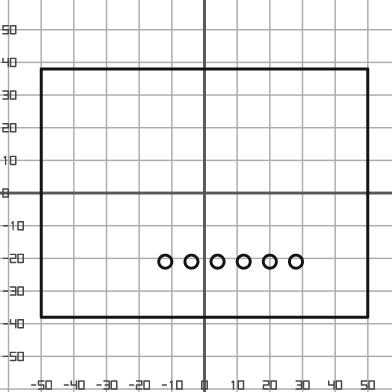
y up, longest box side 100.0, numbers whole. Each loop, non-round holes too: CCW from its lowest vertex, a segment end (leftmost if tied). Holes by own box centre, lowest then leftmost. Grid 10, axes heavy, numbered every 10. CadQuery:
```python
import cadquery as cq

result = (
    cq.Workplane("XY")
    .moveTo(-50.0, -38.0)
    .lineTo(50.0, -38.0)
    .lineTo(50.0, 38.0)
    .lineTo(-50.0, 38.0)
    .close()
    .moveTo(-12.0, -21.0)
    .circle(2.0)
    .moveTo(-4.0, -21.0)
    .circle(2.0)
    .moveTo(4.0, -21.0)
    .circle(2.0)
    .moveTo(12.0, -21.0)
    .circle(2.0)
    .moveTo(20.0, -21.0)
    .circle(2.0)
    .moveTo(28.0, -21.0)
    .circle(2.0)
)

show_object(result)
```